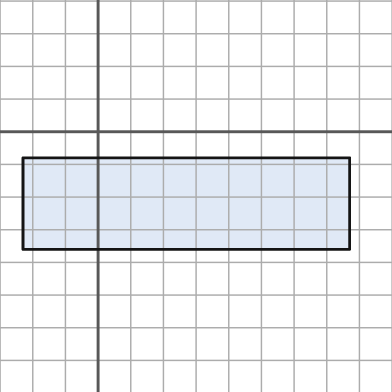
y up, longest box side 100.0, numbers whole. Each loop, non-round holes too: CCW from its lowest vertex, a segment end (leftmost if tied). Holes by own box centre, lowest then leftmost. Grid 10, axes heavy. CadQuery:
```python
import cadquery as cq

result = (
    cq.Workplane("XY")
    .moveTo(-23.0, -36.0)
    .lineTo(77.0, -36.0)
    .lineTo(77.0, -8.0)
    .lineTo(-23.0, -8.0)
    .close()
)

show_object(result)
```